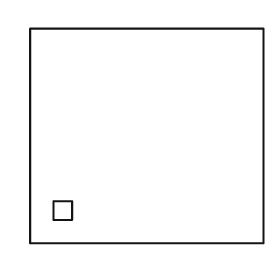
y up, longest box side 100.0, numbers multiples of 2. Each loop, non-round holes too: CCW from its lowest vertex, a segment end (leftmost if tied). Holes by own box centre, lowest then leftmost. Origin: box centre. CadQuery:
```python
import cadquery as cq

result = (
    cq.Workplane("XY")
    .moveTo(-50.0, -46.0)
    .lineTo(50.0, -46.0)
    .lineTo(50.0, 46.0)
    .lineTo(-50.0, 46.0)
    .close()
    .moveTo(-40.0, -36.0)
    .lineTo(-32.0, -36.0)
    .lineTo(-32.0, -28.0)
    .lineTo(-40.0, -28.0)
    .close()
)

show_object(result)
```